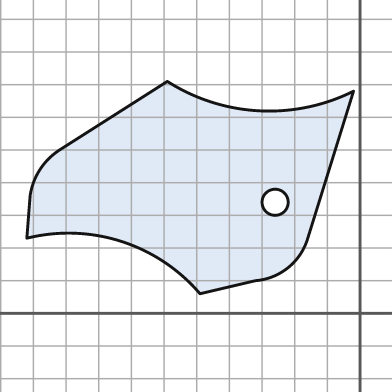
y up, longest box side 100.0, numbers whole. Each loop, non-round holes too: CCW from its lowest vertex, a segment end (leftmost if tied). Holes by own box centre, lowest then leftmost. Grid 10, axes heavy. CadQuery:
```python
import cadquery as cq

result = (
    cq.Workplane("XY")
    .moveTo(-49.0, 6.0)
    .lineTo(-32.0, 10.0)
    .threePointArc((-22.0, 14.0), (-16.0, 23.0))
    .lineTo(-2.0, 68.0)
    .threePointArc((-31.0, 62.0), (-59.0, 71.0))
    .lineTo(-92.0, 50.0)
    .threePointArc((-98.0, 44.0), (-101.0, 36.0))
    .lineTo(-102.0, 23.0)
    .threePointArc((-73.0, 22.0), (-49.0, 6.0))
    .close()
    .moveTo(-26.0, 34.0)
    .circle(4.0)
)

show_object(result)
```